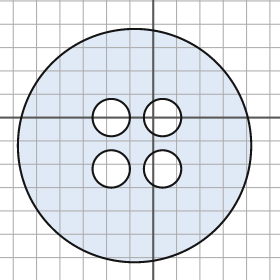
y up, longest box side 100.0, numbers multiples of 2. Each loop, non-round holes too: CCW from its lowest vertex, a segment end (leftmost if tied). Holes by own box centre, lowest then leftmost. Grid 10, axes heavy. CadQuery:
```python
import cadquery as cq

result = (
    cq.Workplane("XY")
    .moveTo(-8.0, -12.0)
    .circle(50.0)
    .moveTo(-18.0, -22.0)
    .circle(8.0)
    .moveTo(4.0, -22.0)
    .circle(8.0)
    .moveTo(-18.0, 0.0)
    .circle(8.0)
    .moveTo(4.0, 0.0)
    .circle(8.0)
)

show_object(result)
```